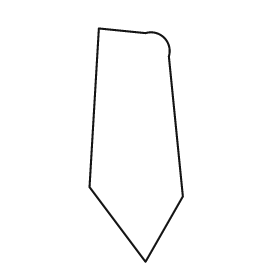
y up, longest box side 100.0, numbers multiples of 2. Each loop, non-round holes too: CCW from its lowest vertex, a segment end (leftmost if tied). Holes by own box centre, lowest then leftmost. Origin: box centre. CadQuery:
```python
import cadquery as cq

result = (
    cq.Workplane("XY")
    .moveTo(4.0, -50.0)
    .lineTo(20.0, -22.0)
    .lineTo(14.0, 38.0)
    .threePointArc((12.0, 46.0), (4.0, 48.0))
    .lineTo(-16.0, 50.0)
    .lineTo(-20.0, -18.0)
    .close()
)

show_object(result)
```